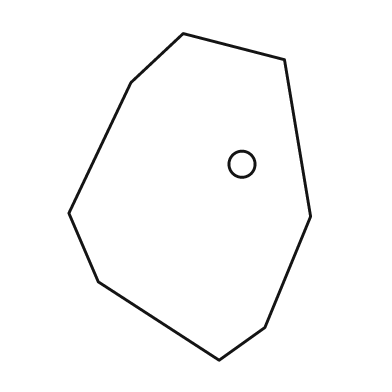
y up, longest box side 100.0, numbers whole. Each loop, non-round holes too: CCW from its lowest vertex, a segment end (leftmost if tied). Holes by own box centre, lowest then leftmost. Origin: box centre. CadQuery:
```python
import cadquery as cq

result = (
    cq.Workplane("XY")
    .moveTo(9.0, -50.0)
    .lineTo(23.0, -40.0)
    .lineTo(37.0, -6.0)
    .lineTo(29.0, 42.0)
    .lineTo(-2.0, 50.0)
    .lineTo(-18.0, 35.0)
    .lineTo(-37.0, -5.0)
    .lineTo(-28.0, -26.0)
    .close()
    .moveTo(16.0, 10.0)
    .circle(4.0)
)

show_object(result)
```